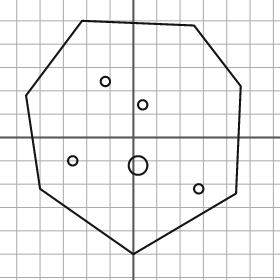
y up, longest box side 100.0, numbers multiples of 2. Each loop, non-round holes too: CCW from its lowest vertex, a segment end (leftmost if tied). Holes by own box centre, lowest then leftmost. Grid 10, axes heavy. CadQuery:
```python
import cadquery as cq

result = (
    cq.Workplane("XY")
    .moveTo(0.0, -50.0)
    .lineTo(44.0, -24.0)
    .lineTo(46.0, 22.0)
    .lineTo(26.0, 48.0)
    .lineTo(-22.0, 50.0)
    .lineTo(-46.0, 18.0)
    .lineTo(-40.0, -22.0)
    .close()
    .moveTo(28.0, -22.0)
    .circle(2.0)
    .moveTo(2.0, -12.0)
    .circle(4.0)
    .moveTo(-26.0, -10.0)
    .circle(2.0)
    .moveTo(4.0, 14.0)
    .circle(2.0)
    .moveTo(-12.0, 24.0)
    .circle(2.0)
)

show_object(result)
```